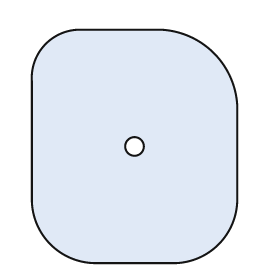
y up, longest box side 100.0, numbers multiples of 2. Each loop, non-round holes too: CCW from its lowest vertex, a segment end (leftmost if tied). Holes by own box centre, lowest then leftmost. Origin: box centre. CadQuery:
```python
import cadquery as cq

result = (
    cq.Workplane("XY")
    .moveTo(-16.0, -50.0)
    .lineTo(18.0, -50.0)
    .threePointArc((36.0, -42.0), (44.0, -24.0))
    .lineTo(44.0, 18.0)
    .threePointArc((34.0, 40.0), (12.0, 50.0))
    .lineTo(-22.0, 50.0)
    .threePointArc((-38.0, 44.0), (-44.0, 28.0))
    .lineTo(-44.0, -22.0)
    .threePointArc((-36.0, -42.0), (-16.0, -50.0))
    .close()
    .moveTo(0.0, 0.0)
    .circle(4.0)
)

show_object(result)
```